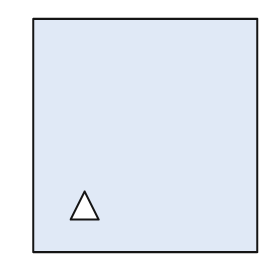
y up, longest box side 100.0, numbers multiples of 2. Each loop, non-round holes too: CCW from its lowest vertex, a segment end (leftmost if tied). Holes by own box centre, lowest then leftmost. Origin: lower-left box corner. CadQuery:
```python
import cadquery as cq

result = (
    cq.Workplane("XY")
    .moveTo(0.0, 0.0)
    .lineTo(96.0, 0.0)
    .lineTo(96.0, 100.0)
    .lineTo(0.0, 100.0)
    .close()
    .moveTo(16.0, 14.0)
    .lineTo(28.0, 14.0)
    .lineTo(22.0, 26.0)
    .close()
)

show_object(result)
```